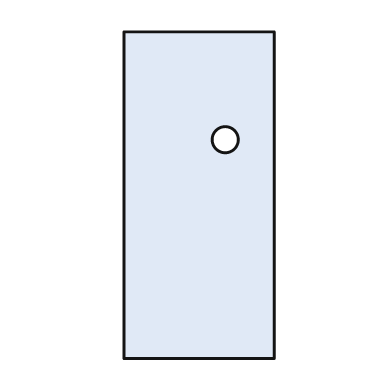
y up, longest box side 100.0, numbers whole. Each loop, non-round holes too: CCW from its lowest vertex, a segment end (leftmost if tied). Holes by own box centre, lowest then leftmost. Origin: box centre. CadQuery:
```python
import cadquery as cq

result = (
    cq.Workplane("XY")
    .moveTo(-23.0, -50.0)
    .lineTo(23.0, -50.0)
    .lineTo(23.0, 50.0)
    .lineTo(-23.0, 50.0)
    .close()
    .moveTo(8.0, 17.0)
    .circle(4.0)
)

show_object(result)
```